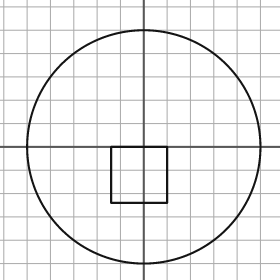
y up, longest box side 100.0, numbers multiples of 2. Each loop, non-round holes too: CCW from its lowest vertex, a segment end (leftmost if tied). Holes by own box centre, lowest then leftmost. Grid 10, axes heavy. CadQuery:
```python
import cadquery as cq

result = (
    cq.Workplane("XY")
    .moveTo(0.0, 0.0)
    .circle(50.0)
    .moveTo(-14.0, -24.0)
    .lineTo(10.0, -24.0)
    .lineTo(10.0, 0.0)
    .lineTo(-14.0, 0.0)
    .close()
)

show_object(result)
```